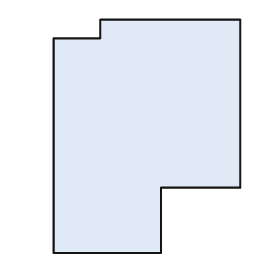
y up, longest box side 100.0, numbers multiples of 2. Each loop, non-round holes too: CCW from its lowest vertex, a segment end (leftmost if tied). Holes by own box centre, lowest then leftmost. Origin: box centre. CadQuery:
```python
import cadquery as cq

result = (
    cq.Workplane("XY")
    .moveTo(-40.0, -50.0)
    .lineTo(6.0, -50.0)
    .lineTo(6.0, -22.0)
    .lineTo(40.0, -22.0)
    .lineTo(40.0, 50.0)
    .lineTo(-20.0, 50.0)
    .lineTo(-20.0, 42.0)
    .lineTo(-40.0, 42.0)
    .close()
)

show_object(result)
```